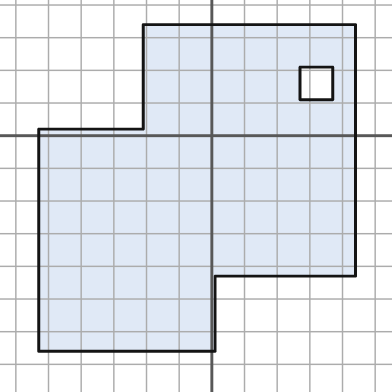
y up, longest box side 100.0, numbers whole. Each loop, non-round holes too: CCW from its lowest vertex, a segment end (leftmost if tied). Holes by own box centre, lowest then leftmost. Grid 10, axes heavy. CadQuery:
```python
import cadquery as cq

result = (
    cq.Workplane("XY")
    .moveTo(-53.0, -66.0)
    .lineTo(1.0, -66.0)
    .lineTo(1.0, -43.0)
    .lineTo(44.0, -43.0)
    .lineTo(44.0, 34.0)
    .lineTo(-21.0, 34.0)
    .lineTo(-21.0, 2.0)
    .lineTo(-53.0, 2.0)
    .close()
    .moveTo(27.0, 11.0)
    .lineTo(37.0, 11.0)
    .lineTo(37.0, 21.0)
    .lineTo(27.0, 21.0)
    .close()
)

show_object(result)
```